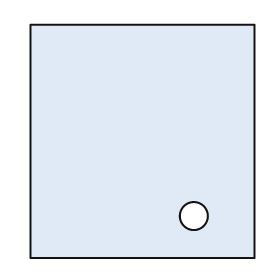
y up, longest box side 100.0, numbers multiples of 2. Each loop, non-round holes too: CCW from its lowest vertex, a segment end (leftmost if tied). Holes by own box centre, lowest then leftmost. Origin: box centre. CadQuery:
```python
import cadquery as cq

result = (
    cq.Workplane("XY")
    .moveTo(-48.0, -50.0)
    .lineTo(48.0, -50.0)
    .lineTo(48.0, 50.0)
    .lineTo(-48.0, 50.0)
    .close()
    .moveTo(22.0, -32.0)
    .circle(6.0)
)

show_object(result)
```